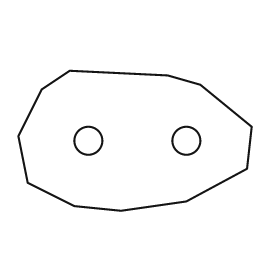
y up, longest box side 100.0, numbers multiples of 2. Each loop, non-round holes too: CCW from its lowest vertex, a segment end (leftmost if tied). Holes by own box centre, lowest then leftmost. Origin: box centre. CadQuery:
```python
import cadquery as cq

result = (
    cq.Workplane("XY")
    .moveTo(-6.0, -30.0)
    .lineTo(22.0, -26.0)
    .lineTo(48.0, -12.0)
    .lineTo(50.0, 6.0)
    .lineTo(28.0, 24.0)
    .lineTo(14.0, 28.0)
    .lineTo(-28.0, 30.0)
    .lineTo(-40.0, 22.0)
    .lineTo(-50.0, 2.0)
    .lineTo(-46.0, -18.0)
    .lineTo(-26.0, -28.0)
    .close()
    .moveTo(-20.0, 0.0)
    .circle(6.0)
    .moveTo(22.0, 0.0)
    .circle(6.0)
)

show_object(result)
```